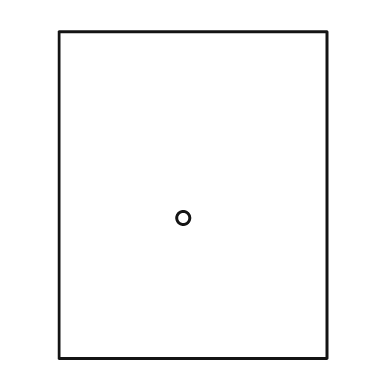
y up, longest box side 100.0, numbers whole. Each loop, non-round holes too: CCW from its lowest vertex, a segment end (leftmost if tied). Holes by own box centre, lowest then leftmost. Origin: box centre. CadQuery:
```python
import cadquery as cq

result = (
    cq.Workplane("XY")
    .moveTo(-41.0, -50.0)
    .lineTo(41.0, -50.0)
    .lineTo(41.0, 50.0)
    .lineTo(-41.0, 50.0)
    .close()
    .moveTo(-3.0, -7.0)
    .circle(2.0)
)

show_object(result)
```